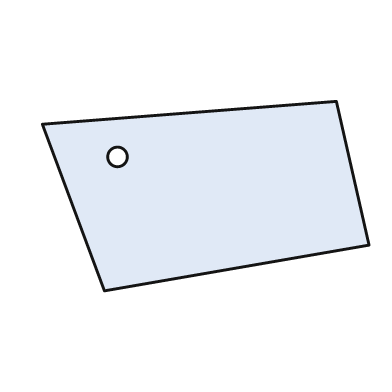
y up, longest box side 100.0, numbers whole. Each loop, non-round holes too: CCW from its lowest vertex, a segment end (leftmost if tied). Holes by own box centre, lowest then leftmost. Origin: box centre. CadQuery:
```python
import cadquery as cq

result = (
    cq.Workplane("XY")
    .moveTo(-31.0, -29.0)
    .lineTo(50.0, -15.0)
    .lineTo(40.0, 29.0)
    .lineTo(-50.0, 22.0)
    .close()
    .moveTo(-27.0, 12.0)
    .circle(3.0)
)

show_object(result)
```